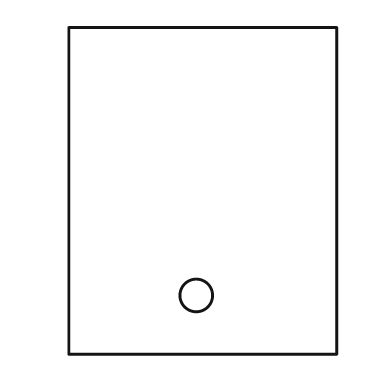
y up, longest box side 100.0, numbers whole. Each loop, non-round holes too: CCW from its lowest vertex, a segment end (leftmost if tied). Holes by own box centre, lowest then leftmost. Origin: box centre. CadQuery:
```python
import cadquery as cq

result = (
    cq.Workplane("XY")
    .moveTo(-41.0, -50.0)
    .lineTo(41.0, -50.0)
    .lineTo(41.0, 50.0)
    .lineTo(-41.0, 50.0)
    .close()
    .moveTo(-2.0, -32.0)
    .circle(5.0)
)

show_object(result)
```